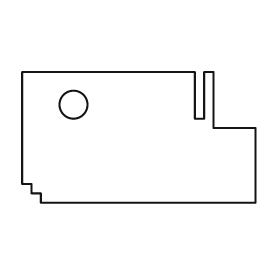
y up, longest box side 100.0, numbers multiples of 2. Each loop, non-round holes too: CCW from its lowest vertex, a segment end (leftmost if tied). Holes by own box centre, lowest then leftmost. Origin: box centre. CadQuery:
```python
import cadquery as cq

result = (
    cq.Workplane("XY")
    .moveTo(-42.0, -28.0)
    .lineTo(50.0, -28.0)
    .lineTo(50.0, 4.0)
    .lineTo(32.0, 4.0)
    .lineTo(32.0, 28.0)
    .lineTo(28.0, 28.0)
    .lineTo(28.0, 8.0)
    .lineTo(24.0, 8.0)
    .lineTo(24.0, 28.0)
    .lineTo(-50.0, 28.0)
    .lineTo(-50.0, -20.0)
    .lineTo(-46.0, -20.0)
    .lineTo(-46.0, -24.0)
    .lineTo(-42.0, -24.0)
    .close()
    .moveTo(-28.0, 14.0)
    .circle(6.0)
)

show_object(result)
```